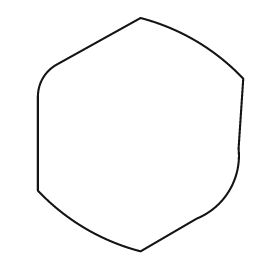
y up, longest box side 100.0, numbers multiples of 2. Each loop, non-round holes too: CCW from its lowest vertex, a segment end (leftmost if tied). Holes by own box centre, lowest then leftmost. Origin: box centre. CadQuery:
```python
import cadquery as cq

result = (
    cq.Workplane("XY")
    .moveTo(0.0, -50.0)
    .lineTo(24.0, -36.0)
    .threePointArc((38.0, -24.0), (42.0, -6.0))
    .lineTo(44.0, 24.0)
    .threePointArc((24.0, 40.0), (0.0, 50.0))
    .lineTo(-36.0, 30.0)
    .threePointArc((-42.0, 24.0), (-44.0, 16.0))
    .lineTo(-44.0, -24.0)
    .threePointArc((-24.0, -40.0), (0.0, -50.0))
    .close()
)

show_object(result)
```